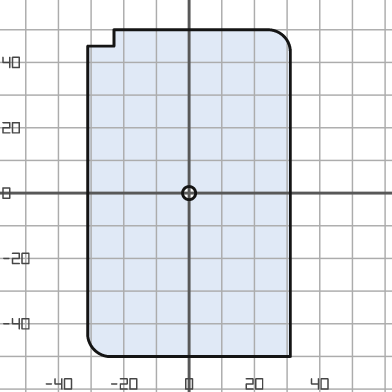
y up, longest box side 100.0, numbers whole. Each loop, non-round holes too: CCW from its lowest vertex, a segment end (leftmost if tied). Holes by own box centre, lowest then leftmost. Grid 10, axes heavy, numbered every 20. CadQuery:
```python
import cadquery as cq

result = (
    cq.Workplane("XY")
    .moveTo(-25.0, -50.0)
    .lineTo(31.0, -50.0)
    .lineTo(31.0, 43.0)
    .threePointArc((29.0, 48.0), (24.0, 50.0))
    .lineTo(-23.0, 50.0)
    .lineTo(-23.0, 45.0)
    .lineTo(-31.0, 45.0)
    .lineTo(-31.0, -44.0)
    .threePointArc((-29.0, -48.0), (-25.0, -50.0))
    .close()
    .moveTo(0.0, 0.0)
    .circle(2.0)
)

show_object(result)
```